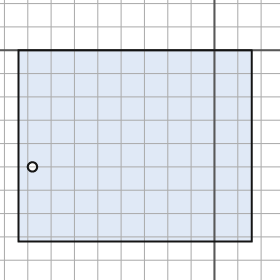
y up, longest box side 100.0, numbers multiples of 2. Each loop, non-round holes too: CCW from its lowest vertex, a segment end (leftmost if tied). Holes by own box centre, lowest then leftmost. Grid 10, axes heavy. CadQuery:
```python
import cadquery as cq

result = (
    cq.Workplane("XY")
    .moveTo(-84.0, -82.0)
    .lineTo(16.0, -82.0)
    .lineTo(16.0, 0.0)
    .lineTo(-84.0, 0.0)
    .close()
    .moveTo(-78.0, -50.0)
    .circle(2.0)
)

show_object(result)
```